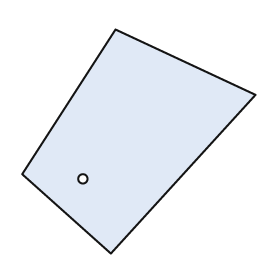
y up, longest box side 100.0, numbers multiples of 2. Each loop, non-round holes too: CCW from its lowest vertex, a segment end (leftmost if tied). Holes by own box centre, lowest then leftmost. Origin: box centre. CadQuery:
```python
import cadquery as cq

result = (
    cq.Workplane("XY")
    .moveTo(-12.0, -48.0)
    .lineTo(50.0, 20.0)
    .lineTo(-10.0, 48.0)
    .lineTo(-50.0, -14.0)
    .close()
    .moveTo(-24.0, -16.0)
    .circle(2.0)
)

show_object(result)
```